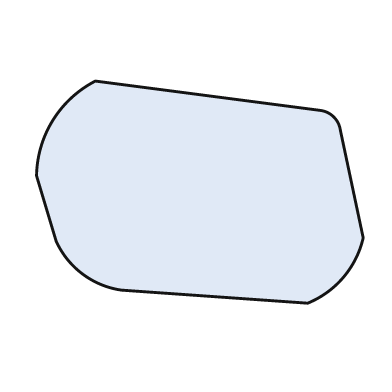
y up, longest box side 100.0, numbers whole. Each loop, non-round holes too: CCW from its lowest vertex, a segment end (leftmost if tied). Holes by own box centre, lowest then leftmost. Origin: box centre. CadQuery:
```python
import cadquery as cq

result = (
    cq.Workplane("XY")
    .moveTo(33.0, -34.0)
    .threePointArc((44.0, -26.0), (50.0, -14.0))
    .lineTo(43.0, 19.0)
    .threePointArc((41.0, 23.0), (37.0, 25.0))
    .lineTo(-32.0, 34.0)
    .threePointArc((-45.0, 22.0), (-50.0, 5.0))
    .lineTo(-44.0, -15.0)
    .threePointArc((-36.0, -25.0), (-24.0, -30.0))
    .close()
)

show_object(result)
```